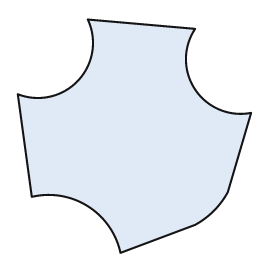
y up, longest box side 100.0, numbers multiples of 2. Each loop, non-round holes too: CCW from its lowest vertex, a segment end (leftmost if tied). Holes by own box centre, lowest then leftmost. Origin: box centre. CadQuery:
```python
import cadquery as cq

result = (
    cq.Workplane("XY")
    .moveTo(-6.0, -50.0)
    .lineTo(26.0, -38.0)
    .threePointArc((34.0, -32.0), (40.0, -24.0))
    .lineTo(50.0, 10.0)
    .threePointArc((26.0, 20.0), (26.0, 46.0))
    .lineTo(-20.0, 50.0)
    .threePointArc((-24.0, 24.0), (-50.0, 18.0))
    .lineTo(-44.0, -26.0)
    .threePointArc((-20.0, -30.0), (-6.0, -50.0))
    .close()
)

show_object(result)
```